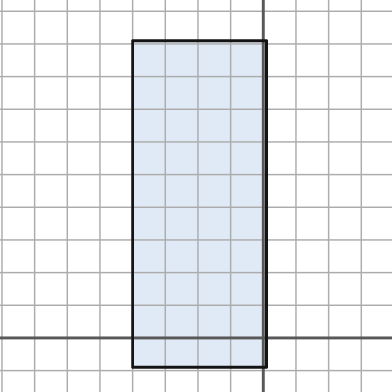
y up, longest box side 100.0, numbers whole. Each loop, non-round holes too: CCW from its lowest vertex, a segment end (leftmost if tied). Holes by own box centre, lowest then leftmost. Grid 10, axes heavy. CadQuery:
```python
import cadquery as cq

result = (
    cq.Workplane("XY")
    .moveTo(-40.0, -9.0)
    .lineTo(1.0, -9.0)
    .lineTo(1.0, 91.0)
    .lineTo(-40.0, 91.0)
    .close()
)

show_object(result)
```